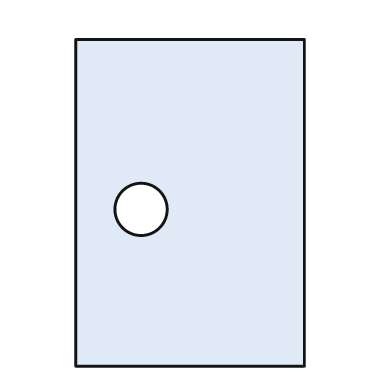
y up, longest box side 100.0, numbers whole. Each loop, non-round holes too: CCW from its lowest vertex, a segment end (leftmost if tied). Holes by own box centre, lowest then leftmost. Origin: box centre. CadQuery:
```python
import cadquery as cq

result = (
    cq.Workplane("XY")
    .moveTo(-35.0, -50.0)
    .lineTo(35.0, -50.0)
    .lineTo(35.0, 50.0)
    .lineTo(-35.0, 50.0)
    .close()
    .moveTo(-15.0, -2.0)
    .circle(8.0)
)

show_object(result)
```